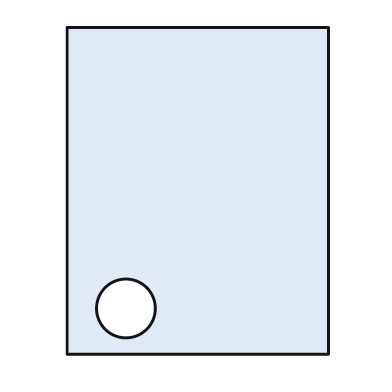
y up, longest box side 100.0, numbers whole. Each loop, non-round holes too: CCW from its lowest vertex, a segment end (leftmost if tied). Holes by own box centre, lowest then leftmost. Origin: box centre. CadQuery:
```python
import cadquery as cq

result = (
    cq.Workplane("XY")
    .moveTo(-40.0, -50.0)
    .lineTo(40.0, -50.0)
    .lineTo(40.0, 50.0)
    .lineTo(-40.0, 50.0)
    .close()
    .moveTo(-22.0, -36.0)
    .circle(9.0)
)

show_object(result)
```